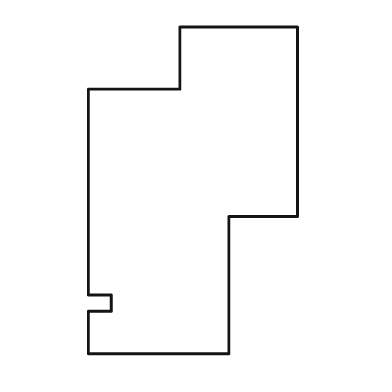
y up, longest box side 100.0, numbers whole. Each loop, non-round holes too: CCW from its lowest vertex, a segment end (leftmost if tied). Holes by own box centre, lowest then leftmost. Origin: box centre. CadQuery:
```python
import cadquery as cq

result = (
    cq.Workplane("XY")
    .moveTo(-32.0, -50.0)
    .lineTo(11.0, -50.0)
    .lineTo(11.0, -8.0)
    .lineTo(32.0, -8.0)
    .lineTo(32.0, 50.0)
    .lineTo(-4.0, 50.0)
    .lineTo(-4.0, 31.0)
    .lineTo(-32.0, 31.0)
    .lineTo(-32.0, -32.0)
    .lineTo(-25.0, -32.0)
    .lineTo(-25.0, -37.0)
    .lineTo(-32.0, -37.0)
    .close()
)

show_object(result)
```